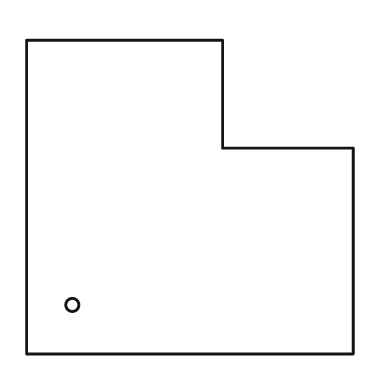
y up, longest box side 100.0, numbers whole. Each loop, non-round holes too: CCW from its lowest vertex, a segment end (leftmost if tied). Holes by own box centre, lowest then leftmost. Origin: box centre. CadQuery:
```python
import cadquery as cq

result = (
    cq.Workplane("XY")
    .moveTo(-50.0, -48.0)
    .lineTo(50.0, -48.0)
    .lineTo(50.0, 15.0)
    .lineTo(10.0, 15.0)
    .lineTo(10.0, 48.0)
    .lineTo(-50.0, 48.0)
    .close()
    .moveTo(-36.0, -33.0)
    .circle(2.0)
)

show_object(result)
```